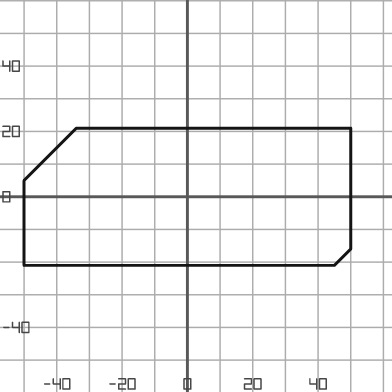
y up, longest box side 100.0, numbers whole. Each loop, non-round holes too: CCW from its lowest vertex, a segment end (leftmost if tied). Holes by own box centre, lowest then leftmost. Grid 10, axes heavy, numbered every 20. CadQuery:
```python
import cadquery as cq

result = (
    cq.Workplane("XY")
    .moveTo(-50.0, -21.0)
    .lineTo(45.0, -21.0)
    .lineTo(50.0, -16.0)
    .lineTo(50.0, 21.0)
    .lineTo(-34.0, 21.0)
    .lineTo(-50.0, 5.0)
    .close()
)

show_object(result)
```